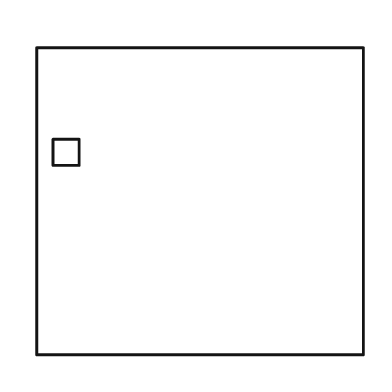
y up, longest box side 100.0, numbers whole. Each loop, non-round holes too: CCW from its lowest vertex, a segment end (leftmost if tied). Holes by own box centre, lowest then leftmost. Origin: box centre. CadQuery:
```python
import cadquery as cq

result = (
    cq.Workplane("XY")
    .moveTo(-50.0, -47.0)
    .lineTo(50.0, -47.0)
    .lineTo(50.0, 47.0)
    .lineTo(-50.0, 47.0)
    .close()
    .moveTo(-45.0, 11.0)
    .lineTo(-37.0, 11.0)
    .lineTo(-37.0, 19.0)
    .lineTo(-45.0, 19.0)
    .close()
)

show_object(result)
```